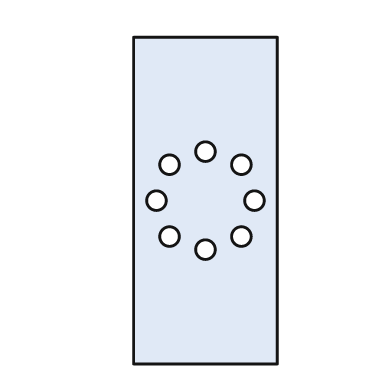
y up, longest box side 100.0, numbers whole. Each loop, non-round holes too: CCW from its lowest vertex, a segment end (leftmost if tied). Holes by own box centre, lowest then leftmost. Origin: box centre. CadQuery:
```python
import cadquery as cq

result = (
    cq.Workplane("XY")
    .moveTo(-22.0, -50.0)
    .lineTo(22.0, -50.0)
    .lineTo(22.0, 50.0)
    .lineTo(-22.0, 50.0)
    .close()
    .moveTo(0.0, -15.0)
    .circle(3.0)
    .moveTo(-11.0, -11.0)
    .circle(3.0)
    .moveTo(11.0, -11.0)
    .circle(3.0)
    .moveTo(-15.0, 0.0)
    .circle(3.0)
    .moveTo(15.0, 0.0)
    .circle(3.0)
    .moveTo(-11.0, 11.0)
    .circle(3.0)
    .moveTo(11.0, 11.0)
    .circle(3.0)
    .moveTo(0.0, 15.0)
    .circle(3.0)
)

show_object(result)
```